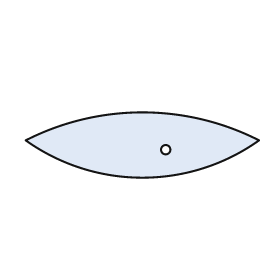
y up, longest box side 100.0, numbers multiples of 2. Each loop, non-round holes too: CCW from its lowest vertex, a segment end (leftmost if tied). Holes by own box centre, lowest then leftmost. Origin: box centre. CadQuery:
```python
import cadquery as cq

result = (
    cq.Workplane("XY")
    .moveTo(-50.0, 2.0)
    .threePointArc((0.0, -14.0), (50.0, 2.0))
    .threePointArc((0.0, 14.0), (-50.0, 2.0))
    .close()
    .moveTo(10.0, -2.0)
    .circle(2.0)
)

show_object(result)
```